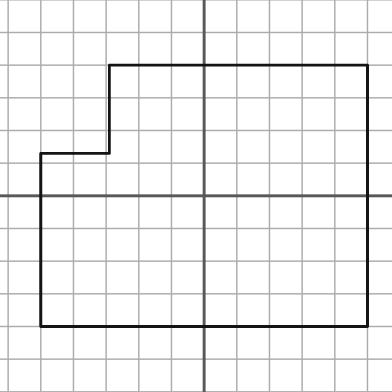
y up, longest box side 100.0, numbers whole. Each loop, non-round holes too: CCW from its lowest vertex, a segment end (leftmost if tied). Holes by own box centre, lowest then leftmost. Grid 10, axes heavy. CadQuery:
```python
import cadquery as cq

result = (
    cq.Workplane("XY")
    .moveTo(-50.0, -40.0)
    .lineTo(50.0, -40.0)
    .lineTo(50.0, 40.0)
    .lineTo(-29.0, 40.0)
    .lineTo(-29.0, 13.0)
    .lineTo(-50.0, 13.0)
    .close()
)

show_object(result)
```